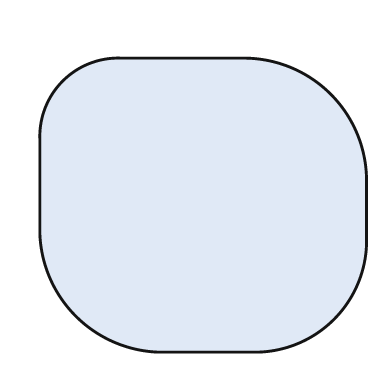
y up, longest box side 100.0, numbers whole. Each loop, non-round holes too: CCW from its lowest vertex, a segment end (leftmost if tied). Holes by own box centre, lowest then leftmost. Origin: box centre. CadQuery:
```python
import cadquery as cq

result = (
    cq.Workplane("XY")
    .moveTo(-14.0, -45.0)
    .lineTo(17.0, -45.0)
    .threePointArc((40.0, -35.0), (50.0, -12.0))
    .lineTo(50.0, 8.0)
    .threePointArc((39.0, 34.0), (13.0, 45.0))
    .lineTo(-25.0, 45.0)
    .threePointArc((-43.0, 38.0), (-50.0, 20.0))
    .lineTo(-50.0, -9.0)
    .threePointArc((-39.0, -34.0), (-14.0, -45.0))
    .close()
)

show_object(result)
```